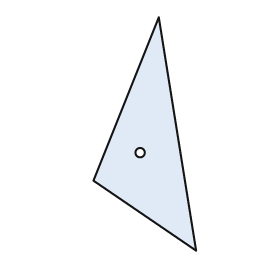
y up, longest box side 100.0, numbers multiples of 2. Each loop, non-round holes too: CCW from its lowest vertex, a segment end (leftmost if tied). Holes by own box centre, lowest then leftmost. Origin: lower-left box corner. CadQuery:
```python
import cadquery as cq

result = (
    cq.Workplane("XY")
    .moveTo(44.0, 0.0)
    .lineTo(28.0, 100.0)
    .lineTo(0.0, 30.0)
    .close()
    .moveTo(20.0, 42.0)
    .circle(2.0)
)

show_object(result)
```